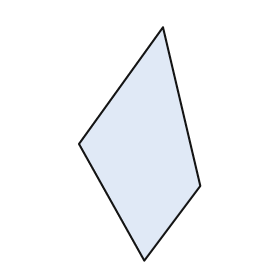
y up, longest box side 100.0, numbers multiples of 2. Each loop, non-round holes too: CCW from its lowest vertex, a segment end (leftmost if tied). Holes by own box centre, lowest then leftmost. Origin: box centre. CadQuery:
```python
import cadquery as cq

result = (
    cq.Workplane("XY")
    .moveTo(2.0, -50.0)
    .lineTo(26.0, -18.0)
    .lineTo(10.0, 50.0)
    .lineTo(-26.0, 0.0)
    .close()
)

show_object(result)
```